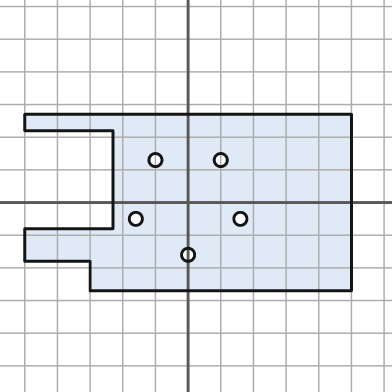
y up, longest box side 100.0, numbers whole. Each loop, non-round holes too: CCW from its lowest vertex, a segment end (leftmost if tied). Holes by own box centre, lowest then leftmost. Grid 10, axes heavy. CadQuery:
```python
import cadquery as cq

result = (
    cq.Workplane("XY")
    .moveTo(-30.0, -27.0)
    .lineTo(50.0, -27.0)
    .lineTo(50.0, 27.0)
    .lineTo(-50.0, 27.0)
    .lineTo(-50.0, 22.0)
    .lineTo(-23.0, 22.0)
    .lineTo(-23.0, -8.0)
    .lineTo(-50.0, -8.0)
    .lineTo(-50.0, -18.0)
    .lineTo(-30.0, -18.0)
    .close()
    .moveTo(0.0, -16.0)
    .circle(2.0)
    .moveTo(-16.0, -5.0)
    .circle(2.0)
    .moveTo(16.0, -5.0)
    .circle(2.0)
    .moveTo(-10.0, 13.0)
    .circle(2.0)
    .moveTo(10.0, 13.0)
    .circle(2.0)
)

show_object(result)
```